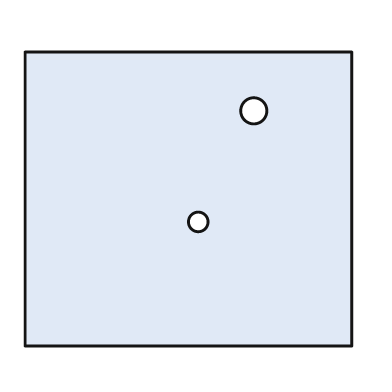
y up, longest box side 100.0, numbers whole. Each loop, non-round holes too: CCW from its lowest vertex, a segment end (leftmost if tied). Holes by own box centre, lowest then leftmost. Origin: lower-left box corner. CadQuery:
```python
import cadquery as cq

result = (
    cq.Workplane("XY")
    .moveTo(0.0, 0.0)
    .lineTo(100.0, 0.0)
    .lineTo(100.0, 90.0)
    .lineTo(0.0, 90.0)
    .close()
    .moveTo(53.0, 38.0)
    .circle(3.0)
    .moveTo(70.0, 72.0)
    .circle(4.0)
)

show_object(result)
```